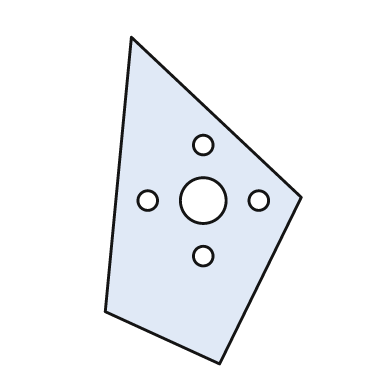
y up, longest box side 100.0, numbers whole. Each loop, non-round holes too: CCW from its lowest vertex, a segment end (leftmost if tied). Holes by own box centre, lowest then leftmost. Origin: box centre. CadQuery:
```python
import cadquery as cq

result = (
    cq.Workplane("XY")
    .moveTo(5.0, -50.0)
    .lineTo(30.0, 1.0)
    .lineTo(-22.0, 50.0)
    .lineTo(-30.0, -34.0)
    .close()
    .moveTo(0.0, -17.0)
    .circle(3.0)
    .moveTo(-17.0, 0.0)
    .circle(3.0)
    .moveTo(0.0, 0.0)
    .circle(7.0)
    .moveTo(17.0, 0.0)
    .circle(3.0)
    .moveTo(0.0, 17.0)
    .circle(3.0)
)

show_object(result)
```